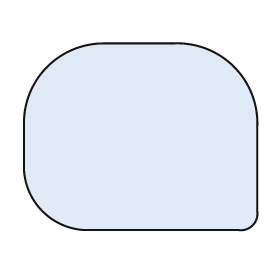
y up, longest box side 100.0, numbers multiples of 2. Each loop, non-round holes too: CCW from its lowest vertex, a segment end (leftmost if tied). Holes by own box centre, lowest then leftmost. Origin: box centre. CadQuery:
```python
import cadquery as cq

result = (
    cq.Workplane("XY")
    .moveTo(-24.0, -40.0)
    .lineTo(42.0, -40.0)
    .threePointArc((48.0, -38.0), (50.0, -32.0))
    .lineTo(50.0, 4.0)
    .threePointArc((40.0, 30.0), (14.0, 40.0))
    .lineTo(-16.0, 40.0)
    .threePointArc((-40.0, 30.0), (-50.0, 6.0))
    .lineTo(-50.0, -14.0)
    .threePointArc((-42.0, -32.0), (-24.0, -40.0))
    .close()
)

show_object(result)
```